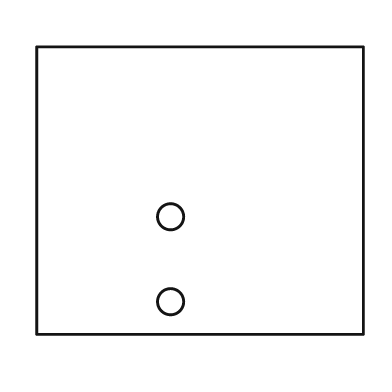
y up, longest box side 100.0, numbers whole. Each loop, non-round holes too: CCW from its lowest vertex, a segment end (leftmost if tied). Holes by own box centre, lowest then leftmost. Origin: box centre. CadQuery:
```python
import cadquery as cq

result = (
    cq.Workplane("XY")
    .moveTo(-50.0, -44.0)
    .lineTo(50.0, -44.0)
    .lineTo(50.0, 44.0)
    .lineTo(-50.0, 44.0)
    .close()
    .moveTo(-9.0, -34.0)
    .circle(4.0)
    .moveTo(-9.0, -8.0)
    .circle(4.0)
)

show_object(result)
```